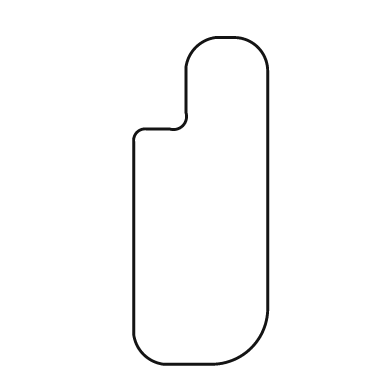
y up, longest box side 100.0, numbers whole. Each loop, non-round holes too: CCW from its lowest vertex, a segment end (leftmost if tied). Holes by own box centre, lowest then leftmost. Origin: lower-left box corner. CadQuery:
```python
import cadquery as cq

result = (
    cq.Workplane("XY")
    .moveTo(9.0, 0.0)
    .lineTo(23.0, 0.0)
    .threePointArc((36.0, 5.0), (41.0, 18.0))
    .lineTo(41.0, 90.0)
    .threePointArc((38.0, 97.0), (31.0, 100.0))
    .lineTo(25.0, 100.0)
    .threePointArc((19.0, 97.0), (16.0, 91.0))
    .lineTo(16.0, 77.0)
    .threePointArc((15.0, 73.0), (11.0, 72.0))
    .lineTo(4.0, 72.0)
    .threePointArc((1.0, 71.0), (0.0, 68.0))
    .lineTo(0.0, 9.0)
    .threePointArc((3.0, 3.0), (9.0, 0.0))
    .close()
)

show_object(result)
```